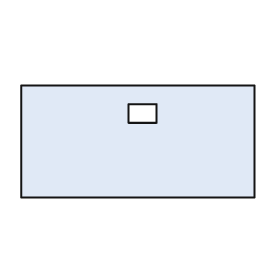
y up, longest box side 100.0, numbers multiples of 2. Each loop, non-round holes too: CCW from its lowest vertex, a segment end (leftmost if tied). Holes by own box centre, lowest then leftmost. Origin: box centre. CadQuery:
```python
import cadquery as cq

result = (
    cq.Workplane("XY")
    .moveTo(-50.0, -24.0)
    .lineTo(50.0, -24.0)
    .lineTo(50.0, 24.0)
    .lineTo(-50.0, 24.0)
    .close()
    .moveTo(-4.0, 8.0)
    .lineTo(8.0, 8.0)
    .lineTo(8.0, 16.0)
    .lineTo(-4.0, 16.0)
    .close()
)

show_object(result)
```